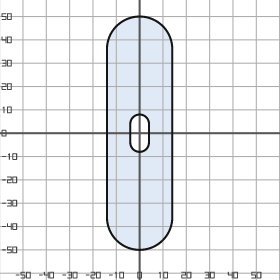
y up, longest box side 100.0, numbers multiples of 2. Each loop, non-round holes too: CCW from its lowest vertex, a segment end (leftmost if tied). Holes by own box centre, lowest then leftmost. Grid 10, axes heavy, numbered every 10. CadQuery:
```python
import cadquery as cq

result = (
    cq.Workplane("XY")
    .moveTo(-14.0, -36.0)
    .threePointArc((0.0, -50.0), (14.0, -36.0))
    .lineTo(14.0, 36.0)
    .threePointArc((0.0, 50.0), (-14.0, 36.0))
    .close()
    .moveTo(-4.0, -4.0)
    .threePointArc((0.0, -8.0), (4.0, -4.0))
    .lineTo(4.0, 4.0)
    .threePointArc((0.0, 8.0), (-4.0, 4.0))
    .close()
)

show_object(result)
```